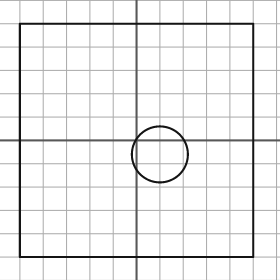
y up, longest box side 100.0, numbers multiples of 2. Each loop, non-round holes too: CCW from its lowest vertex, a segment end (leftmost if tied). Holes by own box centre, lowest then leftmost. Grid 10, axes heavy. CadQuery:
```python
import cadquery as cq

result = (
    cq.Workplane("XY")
    .moveTo(-50.0, -50.0)
    .lineTo(50.0, -50.0)
    .lineTo(50.0, 50.0)
    .lineTo(-50.0, 50.0)
    .close()
    .moveTo(10.0, -6.0)
    .circle(12.0)
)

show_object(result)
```